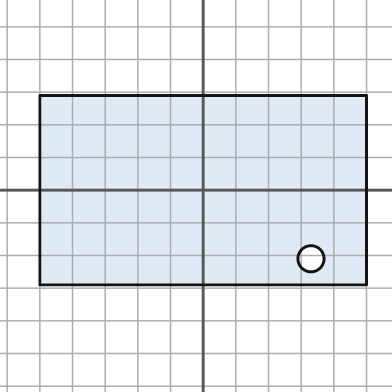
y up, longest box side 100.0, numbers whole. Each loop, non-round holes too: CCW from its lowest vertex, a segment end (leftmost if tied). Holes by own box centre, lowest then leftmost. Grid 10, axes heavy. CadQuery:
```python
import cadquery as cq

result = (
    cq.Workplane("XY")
    .moveTo(-50.0, -29.0)
    .lineTo(50.0, -29.0)
    .lineTo(50.0, 29.0)
    .lineTo(-50.0, 29.0)
    .close()
    .moveTo(33.0, -21.0)
    .circle(4.0)
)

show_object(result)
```